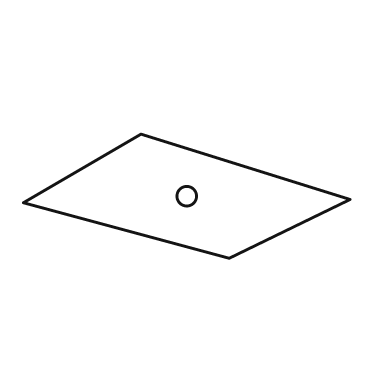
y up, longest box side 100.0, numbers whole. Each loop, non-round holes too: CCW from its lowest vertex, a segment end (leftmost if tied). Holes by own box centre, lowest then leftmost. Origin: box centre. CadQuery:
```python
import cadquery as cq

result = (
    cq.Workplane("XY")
    .moveTo(13.0, -19.0)
    .lineTo(50.0, -1.0)
    .lineTo(-14.0, 19.0)
    .lineTo(-50.0, -2.0)
    .close()
    .moveTo(0.0, 0.0)
    .circle(3.0)
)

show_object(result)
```